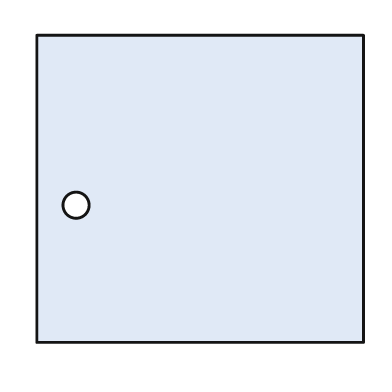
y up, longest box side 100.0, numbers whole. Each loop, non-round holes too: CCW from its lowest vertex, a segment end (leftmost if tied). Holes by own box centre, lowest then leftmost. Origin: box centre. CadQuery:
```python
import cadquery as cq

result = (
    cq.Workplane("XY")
    .moveTo(-50.0, -47.0)
    .lineTo(50.0, -47.0)
    .lineTo(50.0, 47.0)
    .lineTo(-50.0, 47.0)
    .close()
    .moveTo(-38.0, -5.0)
    .circle(4.0)
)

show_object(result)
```